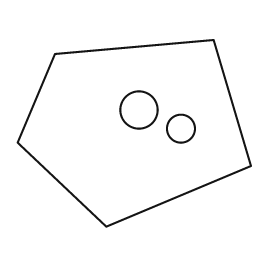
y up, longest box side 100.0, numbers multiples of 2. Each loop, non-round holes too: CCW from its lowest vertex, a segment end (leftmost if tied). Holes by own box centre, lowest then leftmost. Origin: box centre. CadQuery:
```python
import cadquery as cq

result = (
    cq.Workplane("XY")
    .moveTo(-12.0, -40.0)
    .lineTo(50.0, -14.0)
    .lineTo(34.0, 40.0)
    .lineTo(-34.0, 34.0)
    .lineTo(-50.0, -4.0)
    .close()
    .moveTo(20.0, 2.0)
    .circle(6.0)
    .moveTo(2.0, 10.0)
    .circle(8.0)
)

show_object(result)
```